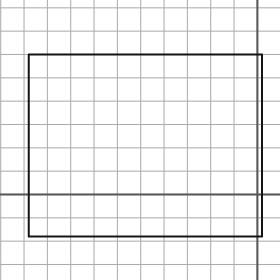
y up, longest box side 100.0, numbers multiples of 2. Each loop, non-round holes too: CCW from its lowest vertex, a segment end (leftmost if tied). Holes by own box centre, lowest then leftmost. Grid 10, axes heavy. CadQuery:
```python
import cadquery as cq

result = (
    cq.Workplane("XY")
    .moveTo(-98.0, -18.0)
    .lineTo(2.0, -18.0)
    .lineTo(2.0, 60.0)
    .lineTo(-98.0, 60.0)
    .close()
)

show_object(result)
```